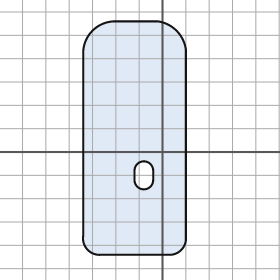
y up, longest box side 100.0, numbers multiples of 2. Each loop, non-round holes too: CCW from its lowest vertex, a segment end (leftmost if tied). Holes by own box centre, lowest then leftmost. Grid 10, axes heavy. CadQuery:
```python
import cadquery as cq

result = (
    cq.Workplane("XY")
    .moveTo(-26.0, -44.0)
    .lineTo(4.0, -44.0)
    .threePointArc((8.0, -42.0), (10.0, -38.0))
    .lineTo(10.0, 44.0)
    .threePointArc((6.0, 52.0), (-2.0, 56.0))
    .lineTo(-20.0, 56.0)
    .threePointArc((-30.0, 52.0), (-34.0, 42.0))
    .lineTo(-34.0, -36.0)
    .threePointArc((-32.0, -42.0), (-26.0, -44.0))
    .close()
    .moveTo(-12.0, -12.0)
    .threePointArc((-8.0, -16.0), (-4.0, -12.0))
    .lineTo(-4.0, -8.0)
    .threePointArc((-8.0, -4.0), (-12.0, -8.0))
    .close()
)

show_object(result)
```